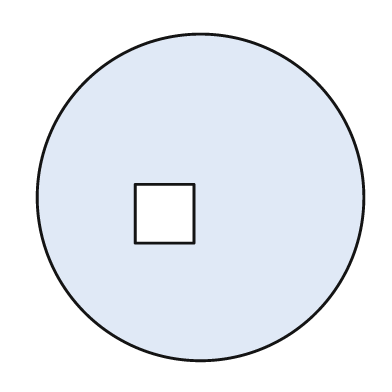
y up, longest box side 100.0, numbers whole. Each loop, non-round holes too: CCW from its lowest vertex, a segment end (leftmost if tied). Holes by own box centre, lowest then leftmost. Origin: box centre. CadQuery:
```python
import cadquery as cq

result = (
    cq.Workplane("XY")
    .moveTo(0.0, 0.0)
    .circle(50.0)
    .moveTo(-20.0, -14.0)
    .lineTo(-2.0, -14.0)
    .lineTo(-2.0, 4.0)
    .lineTo(-20.0, 4.0)
    .close()
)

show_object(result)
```